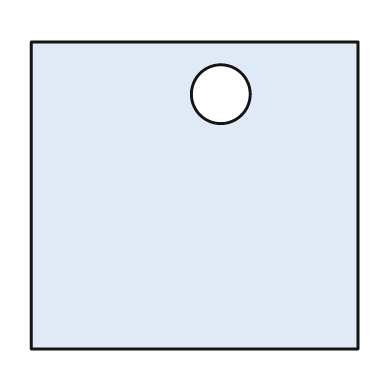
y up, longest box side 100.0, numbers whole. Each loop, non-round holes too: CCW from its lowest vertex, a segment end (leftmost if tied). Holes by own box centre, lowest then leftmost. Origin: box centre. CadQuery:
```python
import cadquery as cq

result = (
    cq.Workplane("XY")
    .moveTo(-50.0, -47.0)
    .lineTo(50.0, -47.0)
    .lineTo(50.0, 47.0)
    .lineTo(-50.0, 47.0)
    .close()
    .moveTo(8.0, 31.0)
    .circle(9.0)
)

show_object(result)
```